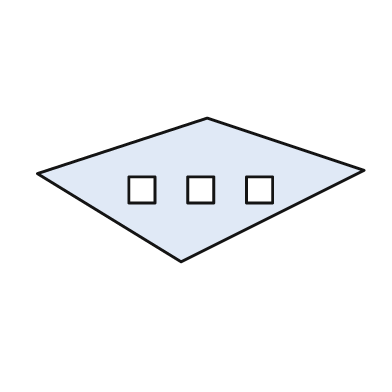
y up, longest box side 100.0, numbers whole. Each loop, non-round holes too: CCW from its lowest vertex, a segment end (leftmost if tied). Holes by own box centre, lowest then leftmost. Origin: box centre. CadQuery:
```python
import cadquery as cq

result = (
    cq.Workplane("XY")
    .moveTo(-6.0, -22.0)
    .lineTo(50.0, 6.0)
    .lineTo(2.0, 22.0)
    .lineTo(-50.0, 5.0)
    .close()
    .moveTo(-22.0, -4.0)
    .lineTo(-14.0, -4.0)
    .lineTo(-14.0, 4.0)
    .lineTo(-22.0, 4.0)
    .close()
    .moveTo(-4.0, -4.0)
    .lineTo(4.0, -4.0)
    .lineTo(4.0, 4.0)
    .lineTo(-4.0, 4.0)
    .close()
    .moveTo(14.0, -4.0)
    .lineTo(22.0, -4.0)
    .lineTo(22.0, 4.0)
    .lineTo(14.0, 4.0)
    .close()
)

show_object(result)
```